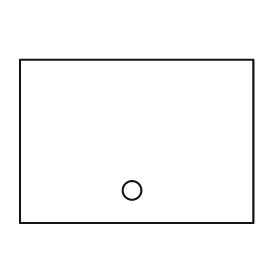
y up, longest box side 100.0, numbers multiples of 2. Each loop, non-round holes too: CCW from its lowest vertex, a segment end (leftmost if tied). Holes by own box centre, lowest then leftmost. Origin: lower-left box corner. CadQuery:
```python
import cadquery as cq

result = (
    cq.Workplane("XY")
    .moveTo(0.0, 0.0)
    .lineTo(100.0, 0.0)
    .lineTo(100.0, 70.0)
    .lineTo(0.0, 70.0)
    .close()
    .moveTo(48.0, 14.0)
    .circle(4.0)
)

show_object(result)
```